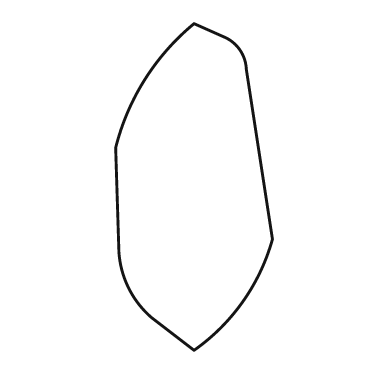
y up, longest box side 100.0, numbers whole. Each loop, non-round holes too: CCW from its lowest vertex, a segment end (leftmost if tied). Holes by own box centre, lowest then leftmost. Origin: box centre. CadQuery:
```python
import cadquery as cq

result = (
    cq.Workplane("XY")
    .moveTo(0.0, -50.0)
    .threePointArc((15.0, -35.0), (24.0, -16.0))
    .lineTo(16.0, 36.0)
    .threePointArc((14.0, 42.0), (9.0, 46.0))
    .lineTo(0.0, 50.0)
    .threePointArc((-15.0, 33.0), (-24.0, 12.0))
    .lineTo(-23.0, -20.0)
    .threePointArc((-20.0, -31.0), (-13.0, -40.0))
    .close()
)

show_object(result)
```